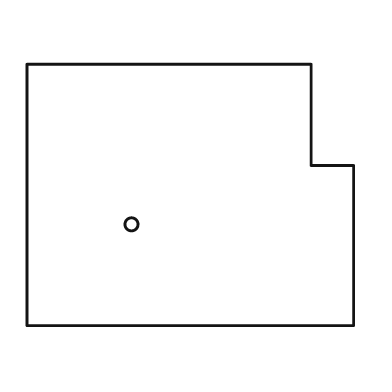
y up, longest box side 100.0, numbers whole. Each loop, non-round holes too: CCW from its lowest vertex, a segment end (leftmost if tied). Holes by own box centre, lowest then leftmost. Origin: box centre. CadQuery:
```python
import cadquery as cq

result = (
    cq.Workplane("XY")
    .moveTo(-50.0, -40.0)
    .lineTo(50.0, -40.0)
    .lineTo(50.0, 9.0)
    .lineTo(37.0, 9.0)
    .lineTo(37.0, 40.0)
    .lineTo(-50.0, 40.0)
    .close()
    .moveTo(-18.0, -9.0)
    .circle(2.0)
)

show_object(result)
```